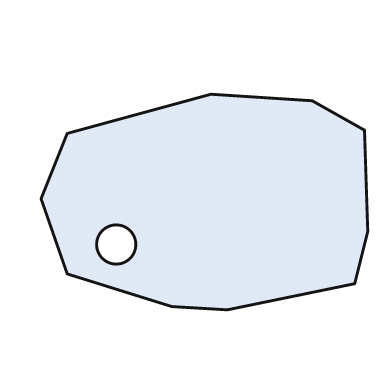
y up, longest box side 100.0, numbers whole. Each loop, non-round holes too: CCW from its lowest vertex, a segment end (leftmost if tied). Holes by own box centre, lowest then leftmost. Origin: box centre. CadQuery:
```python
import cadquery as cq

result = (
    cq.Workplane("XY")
    .moveTo(7.0, -33.0)
    .lineTo(46.0, -25.0)
    .lineTo(50.0, -9.0)
    .lineTo(49.0, 22.0)
    .lineTo(33.0, 31.0)
    .lineTo(2.0, 33.0)
    .lineTo(-42.0, 21.0)
    .lineTo(-50.0, 1.0)
    .lineTo(-42.0, -22.0)
    .lineTo(-10.0, -32.0)
    .close()
    .moveTo(-27.0, -13.0)
    .circle(6.0)
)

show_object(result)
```